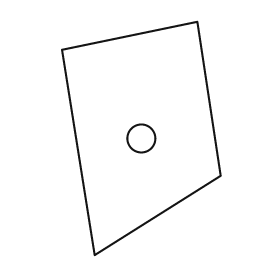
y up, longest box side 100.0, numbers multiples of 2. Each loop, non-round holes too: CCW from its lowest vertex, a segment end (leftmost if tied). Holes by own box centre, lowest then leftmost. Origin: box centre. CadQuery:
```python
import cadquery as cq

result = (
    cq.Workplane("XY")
    .moveTo(-20.0, -50.0)
    .lineTo(34.0, -16.0)
    .lineTo(24.0, 50.0)
    .lineTo(-34.0, 38.0)
    .close()
    .moveTo(0.0, 0.0)
    .circle(6.0)
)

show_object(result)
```